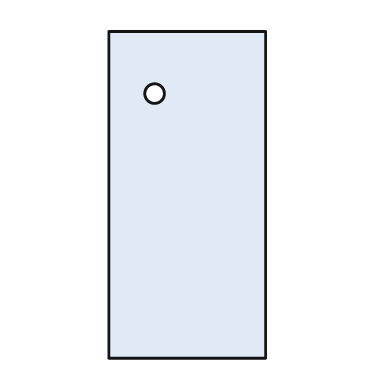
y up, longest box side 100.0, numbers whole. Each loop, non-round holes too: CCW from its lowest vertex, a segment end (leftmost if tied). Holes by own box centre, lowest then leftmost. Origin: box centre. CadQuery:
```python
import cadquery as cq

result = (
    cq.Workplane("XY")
    .moveTo(-24.0, -50.0)
    .lineTo(24.0, -50.0)
    .lineTo(24.0, 50.0)
    .lineTo(-24.0, 50.0)
    .close()
    .moveTo(-10.0, 31.0)
    .circle(3.0)
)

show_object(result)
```